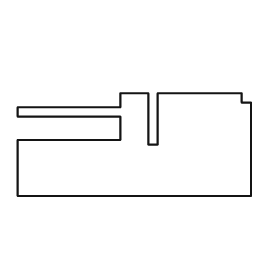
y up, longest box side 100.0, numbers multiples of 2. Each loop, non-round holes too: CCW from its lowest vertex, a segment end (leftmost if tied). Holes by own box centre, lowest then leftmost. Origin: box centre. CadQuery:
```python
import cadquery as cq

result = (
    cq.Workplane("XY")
    .moveTo(-50.0, -22.0)
    .lineTo(50.0, -22.0)
    .lineTo(50.0, 18.0)
    .lineTo(46.0, 18.0)
    .lineTo(46.0, 22.0)
    .lineTo(10.0, 22.0)
    .lineTo(10.0, 0.0)
    .lineTo(6.0, 0.0)
    .lineTo(6.0, 22.0)
    .lineTo(-6.0, 22.0)
    .lineTo(-6.0, 16.0)
    .lineTo(-50.0, 16.0)
    .lineTo(-50.0, 12.0)
    .lineTo(-6.0, 12.0)
    .lineTo(-6.0, 2.0)
    .lineTo(-50.0, 2.0)
    .close()
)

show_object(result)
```